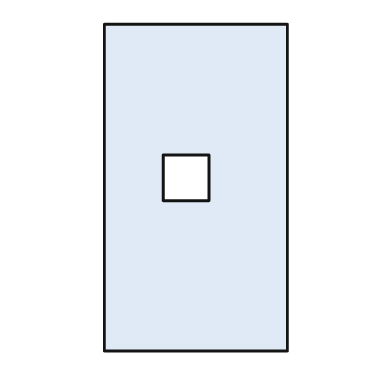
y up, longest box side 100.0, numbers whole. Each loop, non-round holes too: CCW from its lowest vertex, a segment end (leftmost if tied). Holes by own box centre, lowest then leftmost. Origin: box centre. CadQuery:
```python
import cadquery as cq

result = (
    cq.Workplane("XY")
    .moveTo(-28.0, -50.0)
    .lineTo(28.0, -50.0)
    .lineTo(28.0, 50.0)
    .lineTo(-28.0, 50.0)
    .close()
    .moveTo(-10.0, -4.0)
    .lineTo(4.0, -4.0)
    .lineTo(4.0, 10.0)
    .lineTo(-10.0, 10.0)
    .close()
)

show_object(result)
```